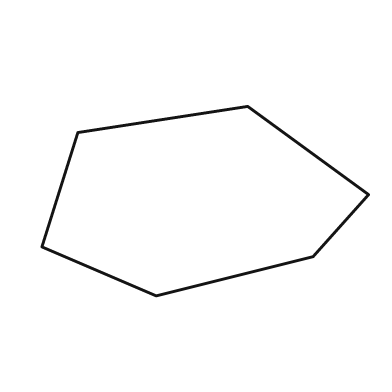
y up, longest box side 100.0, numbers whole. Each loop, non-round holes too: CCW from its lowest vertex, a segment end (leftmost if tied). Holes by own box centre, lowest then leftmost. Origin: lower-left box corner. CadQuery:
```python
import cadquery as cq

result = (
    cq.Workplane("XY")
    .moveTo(35.0, 0.0)
    .lineTo(83.0, 12.0)
    .lineTo(100.0, 31.0)
    .lineTo(63.0, 58.0)
    .lineTo(11.0, 50.0)
    .lineTo(0.0, 15.0)
    .close()
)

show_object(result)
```